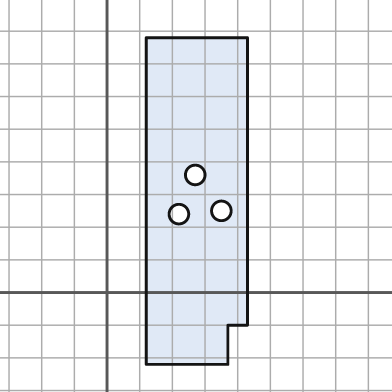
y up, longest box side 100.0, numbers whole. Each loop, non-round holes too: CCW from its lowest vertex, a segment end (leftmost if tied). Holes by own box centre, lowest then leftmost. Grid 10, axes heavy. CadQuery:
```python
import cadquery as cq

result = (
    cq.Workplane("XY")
    .moveTo(12.0, -22.0)
    .lineTo(37.0, -22.0)
    .lineTo(37.0, -10.0)
    .lineTo(43.0, -10.0)
    .lineTo(43.0, 78.0)
    .lineTo(12.0, 78.0)
    .close()
    .moveTo(22.0, 24.0)
    .circle(3.0)
    .moveTo(35.0, 25.0)
    .circle(3.0)
    .moveTo(27.0, 36.0)
    .circle(3.0)
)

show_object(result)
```